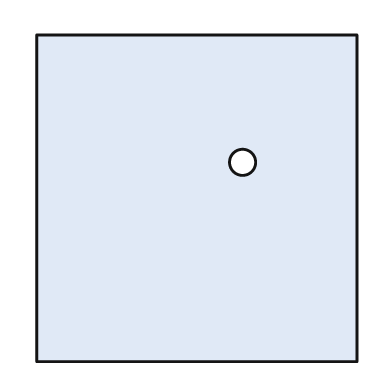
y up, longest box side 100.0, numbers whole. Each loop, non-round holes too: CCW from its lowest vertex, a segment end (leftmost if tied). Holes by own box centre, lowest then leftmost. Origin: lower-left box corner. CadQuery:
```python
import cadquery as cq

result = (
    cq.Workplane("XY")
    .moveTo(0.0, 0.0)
    .lineTo(98.0, 0.0)
    .lineTo(98.0, 100.0)
    .lineTo(0.0, 100.0)
    .close()
    .moveTo(63.0, 61.0)
    .circle(4.0)
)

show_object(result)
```